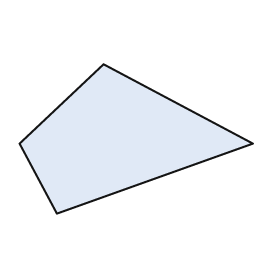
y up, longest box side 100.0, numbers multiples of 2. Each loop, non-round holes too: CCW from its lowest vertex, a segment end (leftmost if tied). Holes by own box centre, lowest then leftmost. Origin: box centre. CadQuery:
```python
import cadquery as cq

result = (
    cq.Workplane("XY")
    .moveTo(-34.0, -32.0)
    .lineTo(50.0, -2.0)
    .lineTo(-14.0, 32.0)
    .lineTo(-50.0, -2.0)
    .close()
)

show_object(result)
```